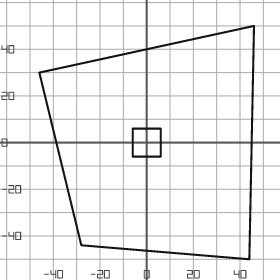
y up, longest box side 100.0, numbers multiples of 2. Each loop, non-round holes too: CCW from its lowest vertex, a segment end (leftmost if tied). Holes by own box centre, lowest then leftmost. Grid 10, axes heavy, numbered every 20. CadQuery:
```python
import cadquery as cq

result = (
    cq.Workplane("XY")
    .moveTo(44.0, -50.0)
    .lineTo(46.0, 50.0)
    .lineTo(-46.0, 30.0)
    .lineTo(-28.0, -44.0)
    .close()
    .moveTo(-6.0, -6.0)
    .lineTo(6.0, -6.0)
    .lineTo(6.0, 6.0)
    .lineTo(-6.0, 6.0)
    .close()
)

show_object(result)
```